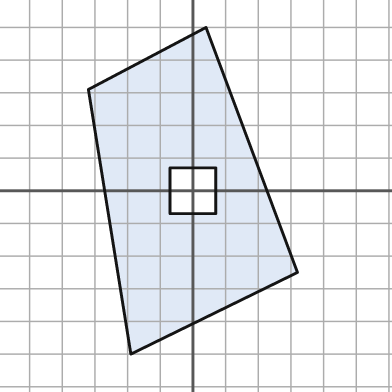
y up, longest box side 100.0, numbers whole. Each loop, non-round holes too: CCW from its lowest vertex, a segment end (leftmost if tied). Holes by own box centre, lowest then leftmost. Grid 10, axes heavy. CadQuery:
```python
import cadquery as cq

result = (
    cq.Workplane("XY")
    .moveTo(-19.0, -50.0)
    .lineTo(32.0, -25.0)
    .lineTo(4.0, 50.0)
    .lineTo(-32.0, 31.0)
    .close()
    .moveTo(-7.0, -7.0)
    .lineTo(7.0, -7.0)
    .lineTo(7.0, 7.0)
    .lineTo(-7.0, 7.0)
    .close()
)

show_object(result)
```